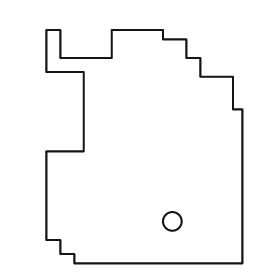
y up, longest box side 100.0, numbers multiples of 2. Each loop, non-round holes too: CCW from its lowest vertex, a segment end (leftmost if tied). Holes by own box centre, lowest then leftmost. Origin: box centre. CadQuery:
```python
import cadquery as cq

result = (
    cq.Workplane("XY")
    .moveTo(-30.0, -50.0)
    .lineTo(42.0, -50.0)
    .lineTo(42.0, 16.0)
    .lineTo(38.0, 16.0)
    .lineTo(38.0, 30.0)
    .lineTo(24.0, 30.0)
    .lineTo(24.0, 38.0)
    .lineTo(18.0, 38.0)
    .lineTo(18.0, 46.0)
    .lineTo(8.0, 46.0)
    .lineTo(8.0, 50.0)
    .lineTo(-14.0, 50.0)
    .lineTo(-14.0, 38.0)
    .lineTo(-36.0, 38.0)
    .lineTo(-36.0, 50.0)
    .lineTo(-42.0, 50.0)
    .lineTo(-42.0, 32.0)
    .lineTo(-26.0, 32.0)
    .lineTo(-26.0, -2.0)
    .lineTo(-42.0, -2.0)
    .lineTo(-42.0, -40.0)
    .lineTo(-36.0, -40.0)
    .lineTo(-36.0, -46.0)
    .lineTo(-30.0, -46.0)
    .close()
    .moveTo(12.0, -32.0)
    .circle(4.0)
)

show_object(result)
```